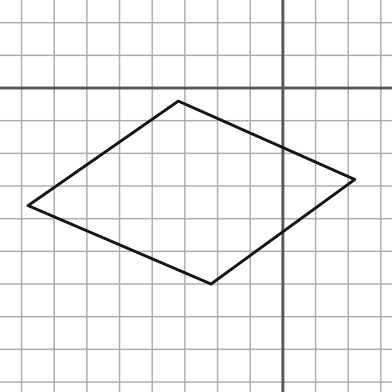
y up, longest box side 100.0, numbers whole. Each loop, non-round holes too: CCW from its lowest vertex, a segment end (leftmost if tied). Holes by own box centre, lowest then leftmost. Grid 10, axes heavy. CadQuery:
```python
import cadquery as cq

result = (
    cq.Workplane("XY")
    .moveTo(-22.0, -60.0)
    .lineTo(22.0, -28.0)
    .lineTo(-32.0, -4.0)
    .lineTo(-78.0, -36.0)
    .close()
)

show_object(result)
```